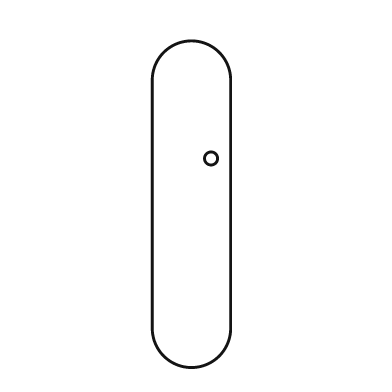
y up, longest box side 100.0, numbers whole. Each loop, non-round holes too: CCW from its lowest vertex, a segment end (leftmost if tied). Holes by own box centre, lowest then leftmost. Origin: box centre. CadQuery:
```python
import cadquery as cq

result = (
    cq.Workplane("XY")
    .moveTo(-12.0, -38.0)
    .threePointArc((0.0, -50.0), (12.0, -38.0))
    .lineTo(12.0, 38.0)
    .threePointArc((0.0, 50.0), (-12.0, 38.0))
    .close()
    .moveTo(6.0, 14.0)
    .circle(2.0)
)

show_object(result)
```